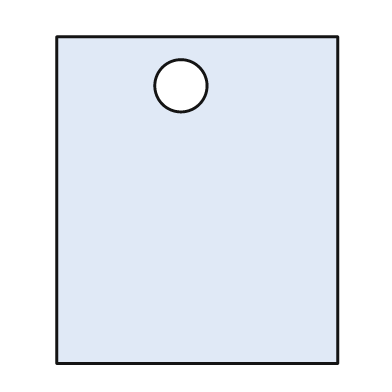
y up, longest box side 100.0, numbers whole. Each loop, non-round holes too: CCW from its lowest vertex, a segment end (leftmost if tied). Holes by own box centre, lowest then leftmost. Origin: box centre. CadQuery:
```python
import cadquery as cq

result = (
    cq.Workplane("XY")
    .moveTo(-43.0, -50.0)
    .lineTo(43.0, -50.0)
    .lineTo(43.0, 50.0)
    .lineTo(-43.0, 50.0)
    .close()
    .moveTo(-5.0, 35.0)
    .circle(8.0)
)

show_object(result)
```